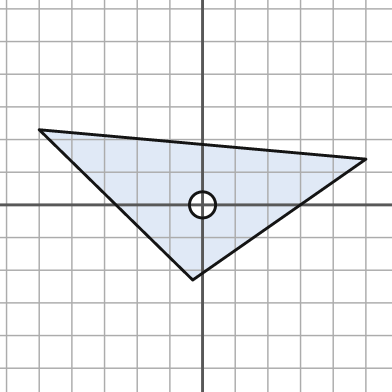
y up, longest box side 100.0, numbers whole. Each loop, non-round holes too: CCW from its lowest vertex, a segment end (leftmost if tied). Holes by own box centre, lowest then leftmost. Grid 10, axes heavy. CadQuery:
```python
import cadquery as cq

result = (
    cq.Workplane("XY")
    .moveTo(-3.0, -23.0)
    .lineTo(50.0, 14.0)
    .lineTo(-50.0, 23.0)
    .close()
    .moveTo(0.0, 0.0)
    .circle(4.0)
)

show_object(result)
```